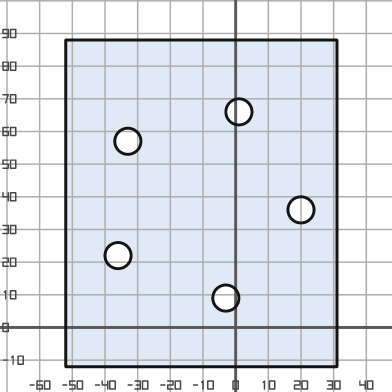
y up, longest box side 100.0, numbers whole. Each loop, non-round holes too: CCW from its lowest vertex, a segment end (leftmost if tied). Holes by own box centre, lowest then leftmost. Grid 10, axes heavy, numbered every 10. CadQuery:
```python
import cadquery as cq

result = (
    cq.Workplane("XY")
    .moveTo(-52.0, -12.0)
    .lineTo(31.0, -12.0)
    .lineTo(31.0, 88.0)
    .lineTo(-52.0, 88.0)
    .close()
    .moveTo(-3.0, 9.0)
    .circle(4.0)
    .moveTo(-36.0, 22.0)
    .circle(4.0)
    .moveTo(20.0, 36.0)
    .circle(4.0)
    .moveTo(-33.0, 57.0)
    .circle(4.0)
    .moveTo(1.0, 66.0)
    .circle(4.0)
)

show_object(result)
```